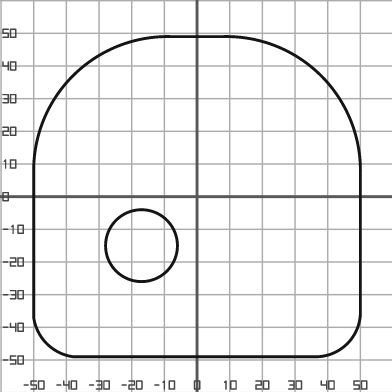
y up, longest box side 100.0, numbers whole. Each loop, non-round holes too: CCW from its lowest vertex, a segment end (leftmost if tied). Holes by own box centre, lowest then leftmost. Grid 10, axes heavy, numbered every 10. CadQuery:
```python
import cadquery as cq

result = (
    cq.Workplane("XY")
    .moveTo(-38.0, -49.0)
    .lineTo(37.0, -49.0)
    .threePointArc((46.0, -45.0), (50.0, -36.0))
    .lineTo(50.0, 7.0)
    .threePointArc((38.0, 37.0), (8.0, 49.0))
    .lineTo(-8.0, 49.0)
    .threePointArc((-38.0, 37.0), (-50.0, 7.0))
    .lineTo(-50.0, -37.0)
    .threePointArc((-46.0, -45.0), (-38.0, -49.0))
    .close()
    .moveTo(-17.0, -15.0)
    .circle(11.0)
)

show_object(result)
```